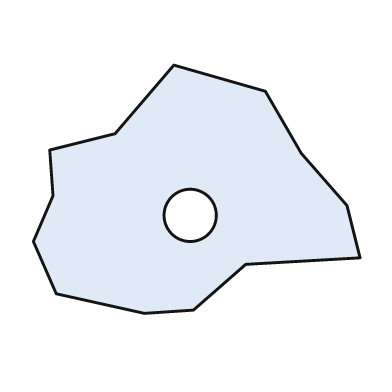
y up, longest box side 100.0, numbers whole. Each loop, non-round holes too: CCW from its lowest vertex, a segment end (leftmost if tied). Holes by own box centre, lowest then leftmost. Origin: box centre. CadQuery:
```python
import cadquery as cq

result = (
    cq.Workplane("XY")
    .moveTo(-16.0, -38.0)
    .lineTo(-1.0, -37.0)
    .lineTo(15.0, -23.0)
    .lineTo(50.0, -21.0)
    .lineTo(46.0, -5.0)
    .lineTo(32.0, 11.0)
    .lineTo(21.0, 30.0)
    .lineTo(-7.0, 38.0)
    .lineTo(-25.0, 17.0)
    .lineTo(-45.0, 12.0)
    .lineTo(-44.0, -2.0)
    .lineTo(-50.0, -16.0)
    .lineTo(-43.0, -32.0)
    .close()
    .moveTo(-2.0, -8.0)
    .circle(8.0)
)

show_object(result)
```